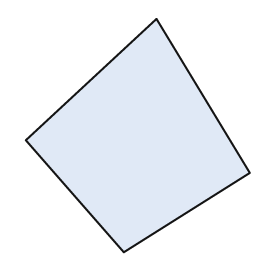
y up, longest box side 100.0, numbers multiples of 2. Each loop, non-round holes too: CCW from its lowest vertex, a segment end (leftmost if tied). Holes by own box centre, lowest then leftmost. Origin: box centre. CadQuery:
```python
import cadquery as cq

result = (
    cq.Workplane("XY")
    .moveTo(-6.0, -50.0)
    .lineTo(48.0, -16.0)
    .lineTo(8.0, 50.0)
    .lineTo(-48.0, -2.0)
    .close()
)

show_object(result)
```